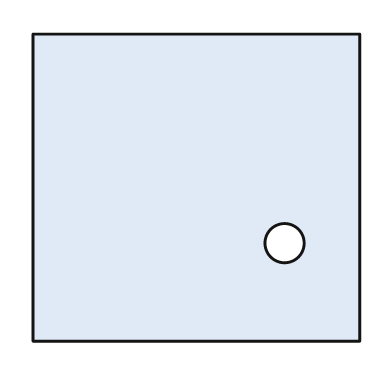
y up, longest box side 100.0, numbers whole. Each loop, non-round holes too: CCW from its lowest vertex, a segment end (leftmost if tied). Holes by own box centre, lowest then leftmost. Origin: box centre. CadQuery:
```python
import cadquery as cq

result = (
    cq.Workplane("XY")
    .moveTo(-50.0, -47.0)
    .lineTo(50.0, -47.0)
    .lineTo(50.0, 47.0)
    .lineTo(-50.0, 47.0)
    .close()
    .moveTo(27.0, -17.0)
    .circle(6.0)
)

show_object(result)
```